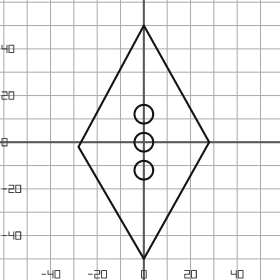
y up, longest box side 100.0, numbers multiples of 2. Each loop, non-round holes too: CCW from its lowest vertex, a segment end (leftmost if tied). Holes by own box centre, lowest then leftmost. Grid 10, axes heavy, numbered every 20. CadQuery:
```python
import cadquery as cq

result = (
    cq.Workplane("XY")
    .moveTo(0.0, -50.0)
    .lineTo(28.0, 0.0)
    .lineTo(0.0, 50.0)
    .lineTo(-28.0, -2.0)
    .close()
    .moveTo(0.0, -12.0)
    .circle(4.0)
    .moveTo(0.0, 0.0)
    .circle(4.0)
    .moveTo(0.0, 12.0)
    .circle(4.0)
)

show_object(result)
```